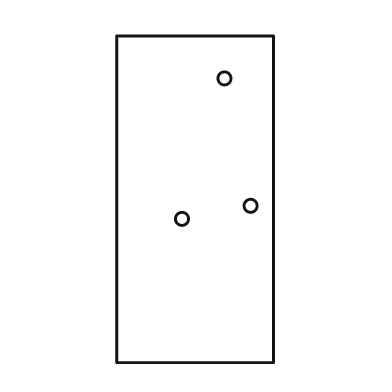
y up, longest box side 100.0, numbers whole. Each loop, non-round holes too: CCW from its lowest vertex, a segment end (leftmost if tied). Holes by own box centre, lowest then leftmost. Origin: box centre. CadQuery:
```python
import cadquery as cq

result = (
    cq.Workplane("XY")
    .moveTo(-24.0, -50.0)
    .lineTo(24.0, -50.0)
    .lineTo(24.0, 50.0)
    .lineTo(-24.0, 50.0)
    .close()
    .moveTo(-4.0, -6.0)
    .circle(2.0)
    .moveTo(17.0, -2.0)
    .circle(2.0)
    .moveTo(9.0, 37.0)
    .circle(2.0)
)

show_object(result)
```